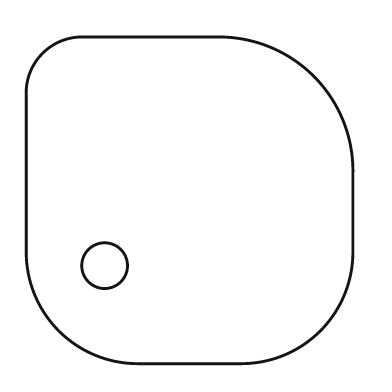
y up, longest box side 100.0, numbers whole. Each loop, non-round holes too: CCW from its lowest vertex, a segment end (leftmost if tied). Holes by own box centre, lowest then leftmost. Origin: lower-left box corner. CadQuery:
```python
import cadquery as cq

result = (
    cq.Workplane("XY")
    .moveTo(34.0, 0.0)
    .lineTo(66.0, 0.0)
    .threePointArc((90.0, 10.0), (100.0, 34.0))
    .lineTo(100.0, 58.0)
    .threePointArc((88.0, 88.0), (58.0, 100.0))
    .lineTo(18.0, 100.0)
    .threePointArc((5.0, 95.0), (0.0, 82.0))
    .lineTo(0.0, 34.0)
    .threePointArc((10.0, 10.0), (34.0, 0.0))
    .close()
    .moveTo(24.0, 30.0)
    .circle(7.0)
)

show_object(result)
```